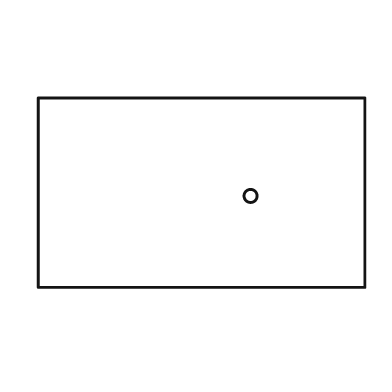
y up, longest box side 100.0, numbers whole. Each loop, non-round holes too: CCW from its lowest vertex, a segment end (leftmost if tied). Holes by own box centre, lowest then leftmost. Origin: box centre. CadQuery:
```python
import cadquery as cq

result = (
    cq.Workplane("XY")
    .moveTo(-50.0, -29.0)
    .lineTo(50.0, -29.0)
    .lineTo(50.0, 29.0)
    .lineTo(-50.0, 29.0)
    .close()
    .moveTo(15.0, -1.0)
    .circle(2.0)
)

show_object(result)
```